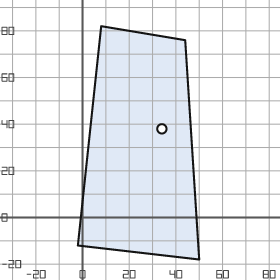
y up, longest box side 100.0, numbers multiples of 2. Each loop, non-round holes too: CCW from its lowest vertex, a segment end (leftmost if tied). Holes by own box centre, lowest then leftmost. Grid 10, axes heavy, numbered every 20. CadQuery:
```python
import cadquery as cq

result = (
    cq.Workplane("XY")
    .moveTo(50.0, -18.0)
    .lineTo(44.0, 76.0)
    .lineTo(8.0, 82.0)
    .lineTo(-2.0, -12.0)
    .close()
    .moveTo(34.0, 38.0)
    .circle(2.0)
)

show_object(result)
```